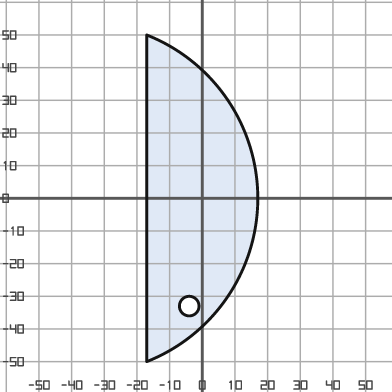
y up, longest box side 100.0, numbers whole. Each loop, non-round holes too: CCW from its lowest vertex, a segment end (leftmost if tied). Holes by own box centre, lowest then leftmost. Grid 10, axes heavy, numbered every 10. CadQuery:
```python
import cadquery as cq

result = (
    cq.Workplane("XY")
    .moveTo(-17.0, -50.0)
    .threePointArc((17.0, 0.0), (-17.0, 50.0))
    .close()
    .moveTo(-4.0, -33.0)
    .circle(3.0)
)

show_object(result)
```